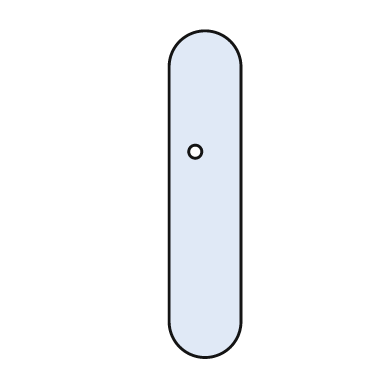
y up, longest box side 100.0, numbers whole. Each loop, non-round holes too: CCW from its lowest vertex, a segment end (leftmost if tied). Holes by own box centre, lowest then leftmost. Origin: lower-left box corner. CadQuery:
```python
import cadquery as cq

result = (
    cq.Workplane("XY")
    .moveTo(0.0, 11.0)
    .threePointArc((11.0, 0.0), (22.0, 11.0))
    .lineTo(22.0, 89.0)
    .threePointArc((11.0, 100.0), (0.0, 89.0))
    .close()
    .moveTo(8.0, 63.0)
    .circle(2.0)
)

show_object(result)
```